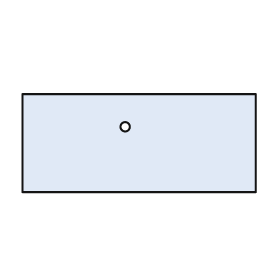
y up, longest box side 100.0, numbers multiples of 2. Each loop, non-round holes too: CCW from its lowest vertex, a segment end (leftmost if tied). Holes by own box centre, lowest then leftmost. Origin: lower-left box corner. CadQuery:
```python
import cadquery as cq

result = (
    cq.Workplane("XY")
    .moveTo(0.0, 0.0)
    .lineTo(100.0, 0.0)
    .lineTo(100.0, 42.0)
    .lineTo(0.0, 42.0)
    .close()
    .moveTo(44.0, 28.0)
    .circle(2.0)
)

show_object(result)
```